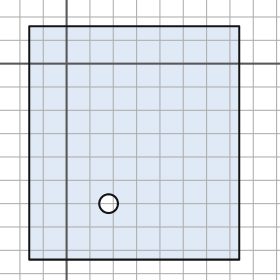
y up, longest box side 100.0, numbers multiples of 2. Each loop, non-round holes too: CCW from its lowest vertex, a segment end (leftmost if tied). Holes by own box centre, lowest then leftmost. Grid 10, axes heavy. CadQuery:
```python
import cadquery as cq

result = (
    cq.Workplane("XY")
    .moveTo(-16.0, -84.0)
    .lineTo(74.0, -84.0)
    .lineTo(74.0, 16.0)
    .lineTo(-16.0, 16.0)
    .close()
    .moveTo(18.0, -60.0)
    .circle(4.0)
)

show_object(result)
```